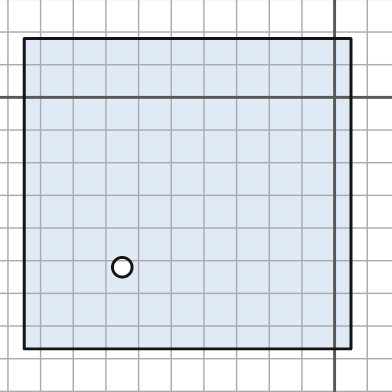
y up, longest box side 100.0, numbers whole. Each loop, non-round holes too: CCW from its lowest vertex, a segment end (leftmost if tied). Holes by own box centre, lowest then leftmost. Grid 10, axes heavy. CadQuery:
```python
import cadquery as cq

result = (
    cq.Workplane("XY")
    .moveTo(-95.0, -77.0)
    .lineTo(5.0, -77.0)
    .lineTo(5.0, 18.0)
    .lineTo(-95.0, 18.0)
    .close()
    .moveTo(-65.0, -52.0)
    .circle(3.0)
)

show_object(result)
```